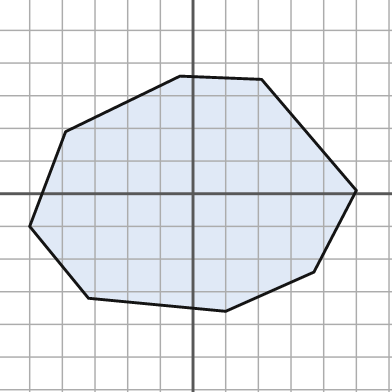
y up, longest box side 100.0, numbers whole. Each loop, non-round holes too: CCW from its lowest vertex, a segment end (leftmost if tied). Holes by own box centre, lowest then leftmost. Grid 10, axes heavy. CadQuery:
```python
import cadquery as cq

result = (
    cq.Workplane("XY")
    .moveTo(10.0, -36.0)
    .lineTo(37.0, -24.0)
    .lineTo(50.0, 1.0)
    .lineTo(21.0, 35.0)
    .lineTo(-4.0, 36.0)
    .lineTo(-39.0, 19.0)
    .lineTo(-50.0, -10.0)
    .lineTo(-32.0, -32.0)
    .close()
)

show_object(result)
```